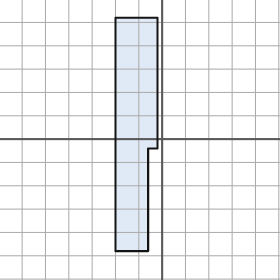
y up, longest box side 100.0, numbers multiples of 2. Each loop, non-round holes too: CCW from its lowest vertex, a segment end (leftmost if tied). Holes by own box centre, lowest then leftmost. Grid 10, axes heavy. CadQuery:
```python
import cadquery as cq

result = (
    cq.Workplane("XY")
    .moveTo(-20.0, -48.0)
    .lineTo(-6.0, -48.0)
    .lineTo(-6.0, -4.0)
    .lineTo(-2.0, -4.0)
    .lineTo(-2.0, 52.0)
    .lineTo(-20.0, 52.0)
    .close()
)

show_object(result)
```